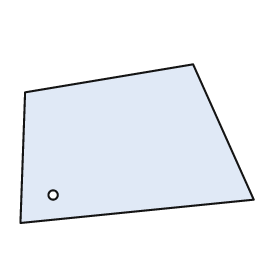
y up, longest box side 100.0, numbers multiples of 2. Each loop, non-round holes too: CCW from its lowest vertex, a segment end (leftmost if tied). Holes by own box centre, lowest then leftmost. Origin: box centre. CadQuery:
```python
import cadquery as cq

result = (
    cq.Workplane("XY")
    .moveTo(-50.0, -34.0)
    .lineTo(50.0, -24.0)
    .lineTo(24.0, 34.0)
    .lineTo(-48.0, 22.0)
    .close()
    .moveTo(-36.0, -22.0)
    .circle(2.0)
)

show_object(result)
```